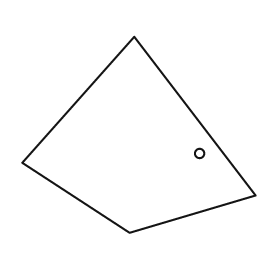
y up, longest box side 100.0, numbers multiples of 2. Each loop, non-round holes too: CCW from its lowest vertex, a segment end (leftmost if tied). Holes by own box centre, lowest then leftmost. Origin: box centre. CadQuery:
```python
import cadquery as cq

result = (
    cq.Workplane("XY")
    .moveTo(-4.0, -42.0)
    .lineTo(50.0, -26.0)
    .lineTo(-2.0, 42.0)
    .lineTo(-50.0, -12.0)
    .close()
    .moveTo(26.0, -8.0)
    .circle(2.0)
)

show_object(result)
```